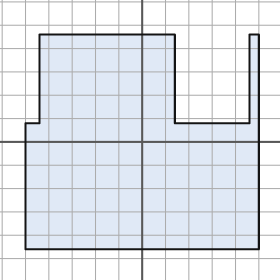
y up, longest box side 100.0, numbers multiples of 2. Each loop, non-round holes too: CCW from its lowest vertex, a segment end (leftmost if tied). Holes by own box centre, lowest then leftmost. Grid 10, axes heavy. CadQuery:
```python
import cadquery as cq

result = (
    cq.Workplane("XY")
    .moveTo(-50.0, -46.0)
    .lineTo(50.0, -46.0)
    .lineTo(50.0, 46.0)
    .lineTo(46.0, 46.0)
    .lineTo(46.0, 8.0)
    .lineTo(14.0, 8.0)
    .lineTo(14.0, 46.0)
    .lineTo(-44.0, 46.0)
    .lineTo(-44.0, 8.0)
    .lineTo(-50.0, 8.0)
    .close()
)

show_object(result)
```